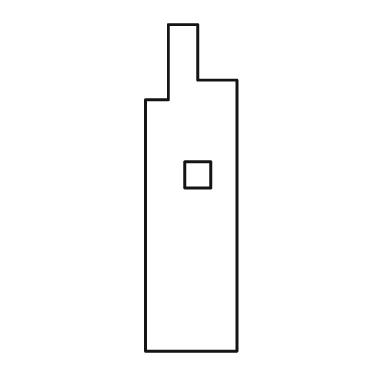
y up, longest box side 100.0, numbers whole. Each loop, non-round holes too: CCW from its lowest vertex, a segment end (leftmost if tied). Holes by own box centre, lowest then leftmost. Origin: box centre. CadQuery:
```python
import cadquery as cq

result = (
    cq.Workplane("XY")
    .moveTo(-14.0, -50.0)
    .lineTo(14.0, -50.0)
    .lineTo(14.0, 33.0)
    .lineTo(2.0, 33.0)
    .lineTo(2.0, 50.0)
    .lineTo(-7.0, 50.0)
    .lineTo(-7.0, 27.0)
    .lineTo(-14.0, 27.0)
    .close()
    .moveTo(-2.0, 0.0)
    .lineTo(6.0, 0.0)
    .lineTo(6.0, 8.0)
    .lineTo(-2.0, 8.0)
    .close()
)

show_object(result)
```